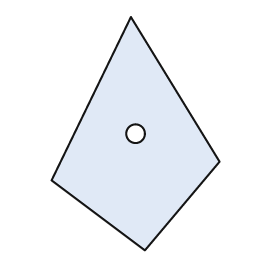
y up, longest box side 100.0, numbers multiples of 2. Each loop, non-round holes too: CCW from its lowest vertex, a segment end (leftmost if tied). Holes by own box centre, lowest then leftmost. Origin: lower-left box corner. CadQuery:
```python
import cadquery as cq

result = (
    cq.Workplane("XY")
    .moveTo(40.0, 0.0)
    .lineTo(72.0, 38.0)
    .lineTo(34.0, 100.0)
    .lineTo(0.0, 30.0)
    .close()
    .moveTo(36.0, 50.0)
    .circle(4.0)
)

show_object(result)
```